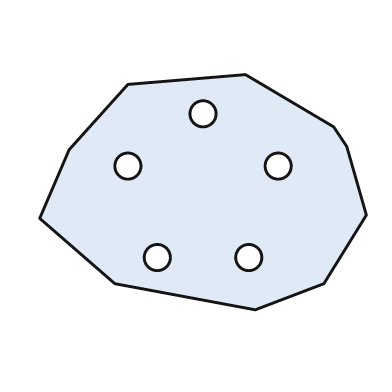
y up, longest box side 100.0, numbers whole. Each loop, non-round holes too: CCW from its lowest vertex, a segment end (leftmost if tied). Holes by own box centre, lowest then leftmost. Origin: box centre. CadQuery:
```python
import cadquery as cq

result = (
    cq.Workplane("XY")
    .moveTo(16.0, -36.0)
    .lineTo(37.0, -28.0)
    .lineTo(50.0, -7.0)
    .lineTo(44.0, 14.0)
    .lineTo(40.0, 20.0)
    .lineTo(13.0, 36.0)
    .lineTo(-23.0, 33.0)
    .lineTo(-41.0, 13.0)
    .lineTo(-50.0, -8.0)
    .lineTo(-27.0, -28.0)
    .close()
    .moveTo(-14.0, -20.0)
    .circle(4.0)
    .moveTo(14.0, -20.0)
    .circle(4.0)
    .moveTo(-23.0, 8.0)
    .circle(4.0)
    .moveTo(23.0, 8.0)
    .circle(4.0)
    .moveTo(0.0, 24.0)
    .circle(4.0)
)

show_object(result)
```